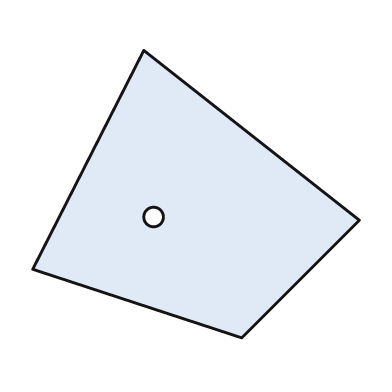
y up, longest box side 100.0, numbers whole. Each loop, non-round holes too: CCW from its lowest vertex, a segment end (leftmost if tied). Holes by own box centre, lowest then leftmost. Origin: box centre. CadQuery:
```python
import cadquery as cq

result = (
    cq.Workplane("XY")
    .moveTo(14.0, -44.0)
    .lineTo(50.0, -8.0)
    .lineTo(-16.0, 44.0)
    .lineTo(-50.0, -23.0)
    .close()
    .moveTo(-13.0, -7.0)
    .circle(3.0)
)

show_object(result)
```